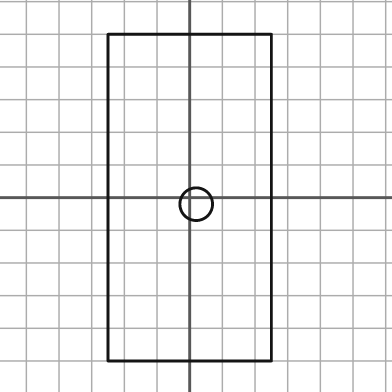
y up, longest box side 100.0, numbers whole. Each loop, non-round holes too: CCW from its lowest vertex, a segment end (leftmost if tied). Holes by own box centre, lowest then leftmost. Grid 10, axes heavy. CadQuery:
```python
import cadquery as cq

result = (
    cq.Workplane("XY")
    .moveTo(-25.0, -50.0)
    .lineTo(25.0, -50.0)
    .lineTo(25.0, 50.0)
    .lineTo(-25.0, 50.0)
    .close()
    .moveTo(2.0, -2.0)
    .circle(5.0)
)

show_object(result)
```